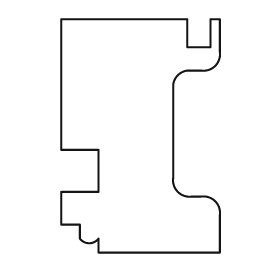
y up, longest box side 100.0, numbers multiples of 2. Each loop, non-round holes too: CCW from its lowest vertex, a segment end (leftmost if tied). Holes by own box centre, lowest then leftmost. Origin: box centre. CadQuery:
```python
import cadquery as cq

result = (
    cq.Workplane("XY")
    .moveTo(-18.0, -50.0)
    .lineTo(34.0, -50.0)
    .lineTo(34.0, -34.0)
    .threePointArc((32.0, -28.0), (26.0, -26.0))
    .lineTo(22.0, -26.0)
    .threePointArc((16.0, -24.0), (14.0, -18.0))
    .lineTo(14.0, 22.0)
    .threePointArc((16.0, 26.0), (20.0, 28.0))
    .lineTo(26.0, 28.0)
    .threePointArc((32.0, 30.0), (34.0, 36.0))
    .lineTo(34.0, 50.0)
    .lineTo(30.0, 50.0)
    .lineTo(30.0, 38.0)
    .lineTo(20.0, 38.0)
    .lineTo(20.0, 50.0)
    .lineTo(-34.0, 50.0)
    .lineTo(-34.0, -6.0)
    .lineTo(-18.0, -6.0)
    .lineTo(-18.0, -24.0)
    .lineTo(-34.0, -24.0)
    .lineTo(-34.0, -38.0)
    .lineTo(-26.0, -38.0)
    .lineTo(-26.0, -44.0)
    .threePointArc((-22.0, -46.0), (-18.0, -44.0))
    .close()
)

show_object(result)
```